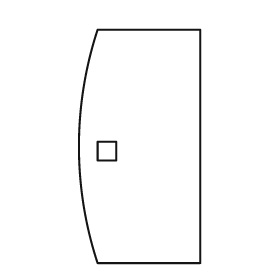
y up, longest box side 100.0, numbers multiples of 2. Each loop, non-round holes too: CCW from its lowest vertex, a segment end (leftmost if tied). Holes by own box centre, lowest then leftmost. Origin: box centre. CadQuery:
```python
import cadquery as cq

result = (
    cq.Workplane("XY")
    .moveTo(-18.0, -50.0)
    .lineTo(26.0, -50.0)
    .lineTo(26.0, 50.0)
    .lineTo(-18.0, 50.0)
    .threePointArc((-26.0, 0.0), (-18.0, -50.0))
    .close()
    .moveTo(-18.0, -6.0)
    .lineTo(-10.0, -6.0)
    .lineTo(-10.0, 2.0)
    .lineTo(-18.0, 2.0)
    .close()
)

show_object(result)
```